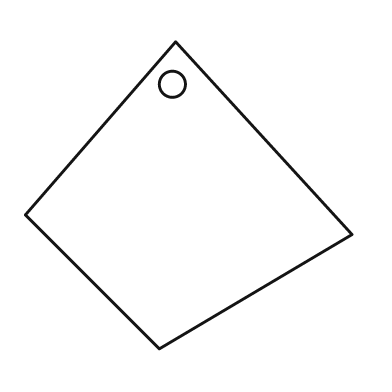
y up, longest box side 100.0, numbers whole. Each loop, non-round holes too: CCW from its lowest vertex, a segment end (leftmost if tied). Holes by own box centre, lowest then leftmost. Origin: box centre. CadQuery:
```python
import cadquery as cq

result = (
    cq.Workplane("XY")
    .moveTo(-9.0, -47.0)
    .lineTo(50.0, -12.0)
    .lineTo(-4.0, 47.0)
    .lineTo(-50.0, -6.0)
    .close()
    .moveTo(-5.0, 34.0)
    .circle(4.0)
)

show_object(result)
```